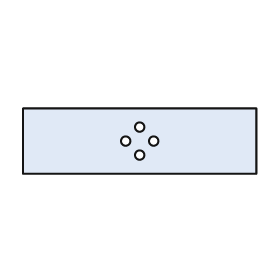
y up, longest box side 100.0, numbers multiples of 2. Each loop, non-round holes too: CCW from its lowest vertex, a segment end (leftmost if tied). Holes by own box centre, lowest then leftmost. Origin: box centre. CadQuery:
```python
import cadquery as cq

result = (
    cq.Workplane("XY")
    .moveTo(-50.0, -14.0)
    .lineTo(50.0, -14.0)
    .lineTo(50.0, 14.0)
    .lineTo(-50.0, 14.0)
    .close()
    .moveTo(0.0, -6.0)
    .circle(2.0)
    .moveTo(-6.0, 0.0)
    .circle(2.0)
    .moveTo(6.0, 0.0)
    .circle(2.0)
    .moveTo(0.0, 6.0)
    .circle(2.0)
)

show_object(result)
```